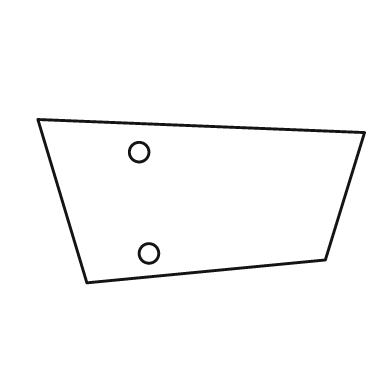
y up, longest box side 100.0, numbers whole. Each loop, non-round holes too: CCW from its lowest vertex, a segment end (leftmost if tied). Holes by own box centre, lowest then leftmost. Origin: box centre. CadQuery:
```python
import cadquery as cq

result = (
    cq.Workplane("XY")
    .moveTo(-35.0, -25.0)
    .lineTo(38.0, -18.0)
    .lineTo(50.0, 21.0)
    .lineTo(-50.0, 25.0)
    .close()
    .moveTo(-16.0, -16.0)
    .circle(3.0)
    .moveTo(-19.0, 15.0)
    .circle(3.0)
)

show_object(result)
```